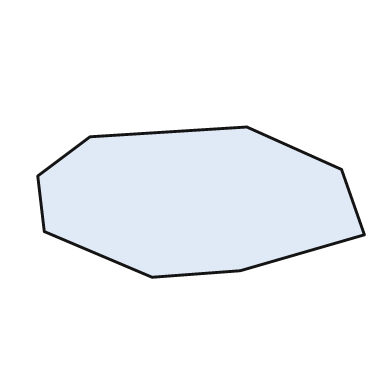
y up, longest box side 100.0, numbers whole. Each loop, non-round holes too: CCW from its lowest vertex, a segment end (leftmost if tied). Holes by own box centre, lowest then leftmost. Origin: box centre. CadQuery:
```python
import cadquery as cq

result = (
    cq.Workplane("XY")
    .moveTo(-15.0, -23.0)
    .lineTo(12.0, -21.0)
    .lineTo(50.0, -10.0)
    .lineTo(43.0, 10.0)
    .lineTo(14.0, 23.0)
    .lineTo(-34.0, 20.0)
    .lineTo(-50.0, 8.0)
    .lineTo(-48.0, -9.0)
    .close()
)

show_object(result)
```